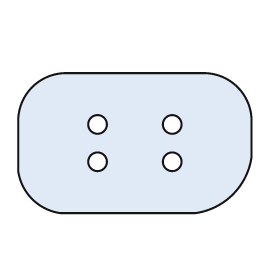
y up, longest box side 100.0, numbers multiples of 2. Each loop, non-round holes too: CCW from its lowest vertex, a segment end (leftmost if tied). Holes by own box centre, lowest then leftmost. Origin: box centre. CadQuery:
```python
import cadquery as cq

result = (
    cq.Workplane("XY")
    .moveTo(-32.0, -30.0)
    .lineTo(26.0, -30.0)
    .threePointArc((42.0, -22.0), (50.0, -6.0))
    .lineTo(50.0, 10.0)
    .threePointArc((44.0, 24.0), (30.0, 30.0))
    .lineTo(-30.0, 30.0)
    .threePointArc((-44.0, 24.0), (-50.0, 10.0))
    .lineTo(-50.0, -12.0)
    .threePointArc((-44.0, -24.0), (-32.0, -30.0))
    .close()
    .moveTo(-16.0, -8.0)
    .circle(4.0)
    .moveTo(16.0, -8.0)
    .circle(4.0)
    .moveTo(-16.0, 8.0)
    .circle(4.0)
    .moveTo(16.0, 8.0)
    .circle(4.0)
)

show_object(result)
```